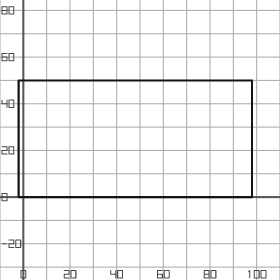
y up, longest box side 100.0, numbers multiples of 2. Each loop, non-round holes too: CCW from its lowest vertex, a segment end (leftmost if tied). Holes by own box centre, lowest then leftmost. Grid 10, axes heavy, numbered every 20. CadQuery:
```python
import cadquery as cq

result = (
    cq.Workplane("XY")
    .moveTo(-2.0, 0.0)
    .lineTo(98.0, 0.0)
    .lineTo(98.0, 50.0)
    .lineTo(-2.0, 50.0)
    .close()
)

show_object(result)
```